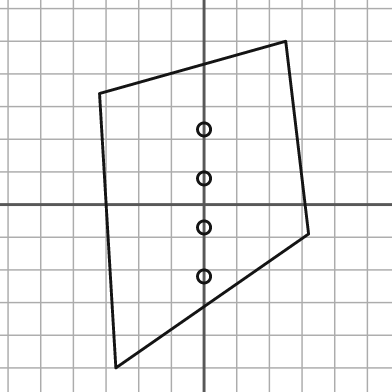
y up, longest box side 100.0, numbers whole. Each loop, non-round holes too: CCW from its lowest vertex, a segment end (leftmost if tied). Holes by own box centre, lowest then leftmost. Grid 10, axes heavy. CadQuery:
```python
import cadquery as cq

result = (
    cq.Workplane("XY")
    .moveTo(-27.0, -50.0)
    .lineTo(32.0, -9.0)
    .lineTo(25.0, 50.0)
    .lineTo(-32.0, 34.0)
    .close()
    .moveTo(0.0, -22.0)
    .circle(2.0)
    .moveTo(0.0, -7.0)
    .circle(2.0)
    .moveTo(0.0, 8.0)
    .circle(2.0)
    .moveTo(0.0, 23.0)
    .circle(2.0)
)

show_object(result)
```